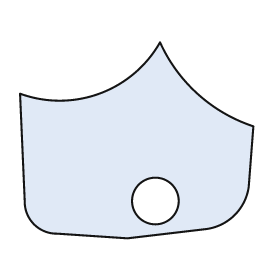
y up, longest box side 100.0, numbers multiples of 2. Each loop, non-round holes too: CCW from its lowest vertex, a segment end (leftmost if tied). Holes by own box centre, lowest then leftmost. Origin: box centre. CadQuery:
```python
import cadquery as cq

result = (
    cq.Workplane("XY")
    .moveTo(-4.0, -42.0)
    .lineTo(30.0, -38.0)
    .threePointArc((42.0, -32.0), (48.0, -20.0))
    .lineTo(50.0, 6.0)
    .threePointArc((26.0, 20.0), (10.0, 42.0))
    .threePointArc((-16.0, 20.0), (-50.0, 20.0))
    .lineTo(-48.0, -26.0)
    .threePointArc((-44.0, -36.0), (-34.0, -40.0))
    .close()
    .moveTo(8.0, -26.0)
    .circle(10.0)
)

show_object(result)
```